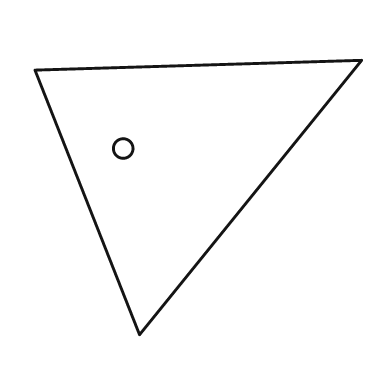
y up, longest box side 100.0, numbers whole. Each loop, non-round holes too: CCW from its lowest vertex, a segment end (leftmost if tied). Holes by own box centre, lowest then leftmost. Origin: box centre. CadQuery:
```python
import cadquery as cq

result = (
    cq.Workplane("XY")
    .moveTo(-18.0, -42.0)
    .lineTo(50.0, 42.0)
    .lineTo(-50.0, 39.0)
    .close()
    .moveTo(-23.0, 15.0)
    .circle(3.0)
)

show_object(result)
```